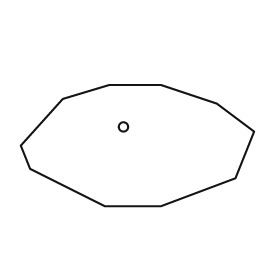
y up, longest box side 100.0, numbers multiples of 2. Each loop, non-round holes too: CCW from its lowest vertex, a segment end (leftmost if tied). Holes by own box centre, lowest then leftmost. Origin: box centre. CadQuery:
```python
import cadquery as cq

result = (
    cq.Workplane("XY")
    .moveTo(-14.0, -26.0)
    .lineTo(10.0, -26.0)
    .lineTo(42.0, -14.0)
    .lineTo(50.0, 6.0)
    .lineTo(34.0, 18.0)
    .lineTo(10.0, 26.0)
    .lineTo(-12.0, 26.0)
    .lineTo(-32.0, 20.0)
    .lineTo(-50.0, 0.0)
    .lineTo(-46.0, -10.0)
    .close()
    .moveTo(-6.0, 8.0)
    .circle(2.0)
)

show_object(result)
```